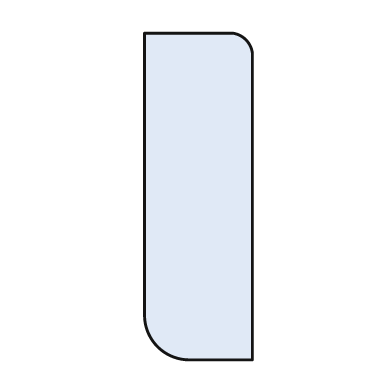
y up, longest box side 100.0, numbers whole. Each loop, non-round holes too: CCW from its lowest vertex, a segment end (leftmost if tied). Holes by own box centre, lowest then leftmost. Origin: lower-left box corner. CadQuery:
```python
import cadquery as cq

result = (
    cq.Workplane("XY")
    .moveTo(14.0, 0.0)
    .lineTo(33.0, 0.0)
    .lineTo(33.0, 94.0)
    .threePointArc((31.0, 98.0), (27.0, 100.0))
    .lineTo(0.0, 100.0)
    .lineTo(0.0, 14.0)
    .threePointArc((4.0, 4.0), (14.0, 0.0))
    .close()
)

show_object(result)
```